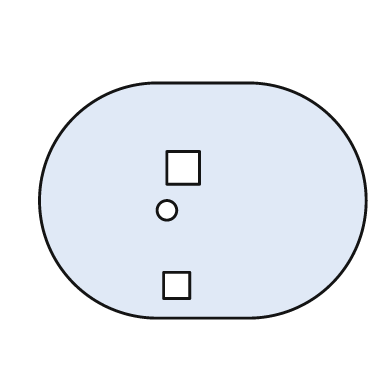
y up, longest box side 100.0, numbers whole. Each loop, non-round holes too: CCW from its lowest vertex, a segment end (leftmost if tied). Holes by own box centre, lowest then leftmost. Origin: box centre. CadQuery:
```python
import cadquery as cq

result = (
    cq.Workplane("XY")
    .moveTo(-14.0, -36.0)
    .lineTo(14.0, -36.0)
    .threePointArc((50.0, 0.0), (14.0, 36.0))
    .lineTo(-14.0, 36.0)
    .threePointArc((-50.0, 0.0), (-14.0, -36.0))
    .close()
    .moveTo(-12.0, -30.0)
    .lineTo(-4.0, -30.0)
    .lineTo(-4.0, -22.0)
    .lineTo(-12.0, -22.0)
    .close()
    .moveTo(-11.0, -3.0)
    .circle(3.0)
    .moveTo(-11.0, 5.0)
    .lineTo(-1.0, 5.0)
    .lineTo(-1.0, 15.0)
    .lineTo(-11.0, 15.0)
    .close()
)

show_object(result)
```